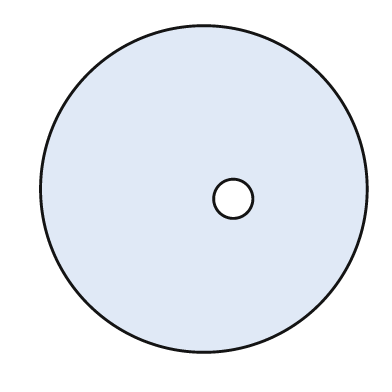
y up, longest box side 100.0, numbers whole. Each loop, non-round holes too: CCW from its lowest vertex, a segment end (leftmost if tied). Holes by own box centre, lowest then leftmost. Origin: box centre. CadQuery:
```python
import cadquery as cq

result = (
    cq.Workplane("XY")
    .moveTo(0.0, 0.0)
    .circle(50.0)
    .moveTo(9.0, -3.0)
    .circle(6.0)
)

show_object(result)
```